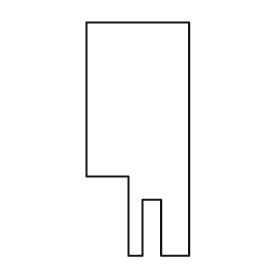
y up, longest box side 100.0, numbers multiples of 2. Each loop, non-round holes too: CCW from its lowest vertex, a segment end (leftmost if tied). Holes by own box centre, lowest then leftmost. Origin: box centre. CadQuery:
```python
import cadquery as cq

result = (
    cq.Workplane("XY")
    .moveTo(-4.0, -50.0)
    .lineTo(2.0, -50.0)
    .lineTo(2.0, -26.0)
    .lineTo(10.0, -26.0)
    .lineTo(10.0, -50.0)
    .lineTo(22.0, -50.0)
    .lineTo(22.0, 50.0)
    .lineTo(-22.0, 50.0)
    .lineTo(-22.0, -16.0)
    .lineTo(-4.0, -16.0)
    .close()
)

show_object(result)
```